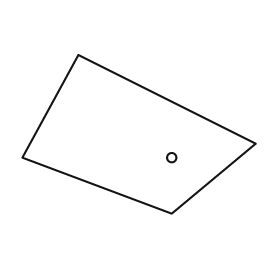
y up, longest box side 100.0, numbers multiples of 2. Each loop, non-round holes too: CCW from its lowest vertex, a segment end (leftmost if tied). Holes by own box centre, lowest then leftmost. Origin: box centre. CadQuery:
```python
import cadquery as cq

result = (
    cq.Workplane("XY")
    .moveTo(14.0, -34.0)
    .lineTo(50.0, -4.0)
    .lineTo(-26.0, 34.0)
    .lineTo(-50.0, -10.0)
    .close()
    .moveTo(14.0, -10.0)
    .circle(2.0)
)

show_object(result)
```